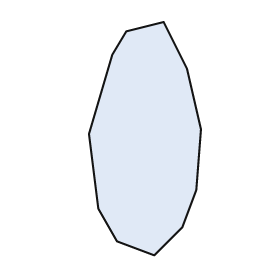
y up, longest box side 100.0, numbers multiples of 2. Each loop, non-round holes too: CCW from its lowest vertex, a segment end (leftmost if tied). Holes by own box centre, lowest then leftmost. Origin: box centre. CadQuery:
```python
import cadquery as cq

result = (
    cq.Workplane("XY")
    .moveTo(4.0, -50.0)
    .lineTo(16.0, -38.0)
    .lineTo(22.0, -22.0)
    .lineTo(24.0, 4.0)
    .lineTo(18.0, 30.0)
    .lineTo(8.0, 50.0)
    .lineTo(-8.0, 46.0)
    .lineTo(-14.0, 36.0)
    .lineTo(-24.0, 2.0)
    .lineTo(-20.0, -30.0)
    .lineTo(-12.0, -44.0)
    .close()
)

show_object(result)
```